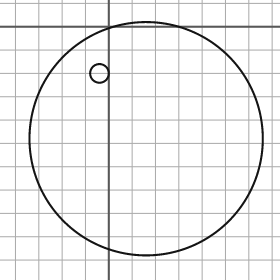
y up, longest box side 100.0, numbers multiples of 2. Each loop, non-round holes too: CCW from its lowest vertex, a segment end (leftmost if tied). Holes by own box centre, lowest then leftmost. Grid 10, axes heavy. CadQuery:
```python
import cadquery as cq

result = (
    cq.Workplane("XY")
    .moveTo(16.0, -48.0)
    .circle(50.0)
    .moveTo(-4.0, -20.0)
    .circle(4.0)
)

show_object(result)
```